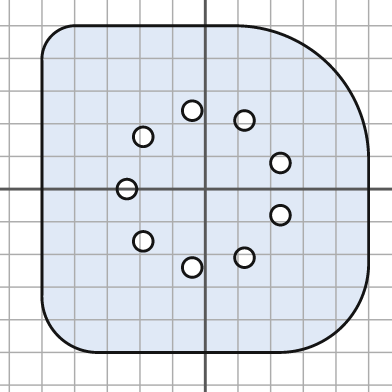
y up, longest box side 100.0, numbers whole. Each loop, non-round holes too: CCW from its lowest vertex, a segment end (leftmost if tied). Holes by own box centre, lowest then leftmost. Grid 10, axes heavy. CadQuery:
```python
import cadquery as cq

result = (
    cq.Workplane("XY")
    .moveTo(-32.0, -50.0)
    .lineTo(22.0, -50.0)
    .threePointArc((42.0, -42.0), (50.0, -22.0))
    .lineTo(50.0, 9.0)
    .threePointArc((38.0, 38.0), (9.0, 50.0))
    .lineTo(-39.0, 50.0)
    .threePointArc((-47.0, 47.0), (-50.0, 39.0))
    .lineTo(-50.0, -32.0)
    .threePointArc((-45.0, -45.0), (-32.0, -50.0))
    .close()
    .moveTo(-4.0, -24.0)
    .circle(3.0)
    .moveTo(12.0, -21.0)
    .circle(3.0)
    .moveTo(-19.0, -16.0)
    .circle(3.0)
    .moveTo(23.0, -8.0)
    .circle(3.0)
    .moveTo(-24.0, 0.0)
    .circle(3.0)
    .moveTo(23.0, 8.0)
    .circle(3.0)
    .moveTo(-19.0, 16.0)
    .circle(3.0)
    .moveTo(12.0, 21.0)
    .circle(3.0)
    .moveTo(-4.0, 24.0)
    .circle(3.0)
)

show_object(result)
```